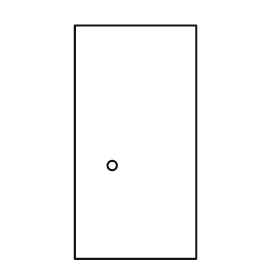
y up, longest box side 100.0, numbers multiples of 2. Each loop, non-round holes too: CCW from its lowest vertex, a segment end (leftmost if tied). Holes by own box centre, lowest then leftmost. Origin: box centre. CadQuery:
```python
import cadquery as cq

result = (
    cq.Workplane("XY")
    .moveTo(-26.0, -50.0)
    .lineTo(26.0, -50.0)
    .lineTo(26.0, 50.0)
    .lineTo(-26.0, 50.0)
    .close()
    .moveTo(-10.0, -10.0)
    .circle(2.0)
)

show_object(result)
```